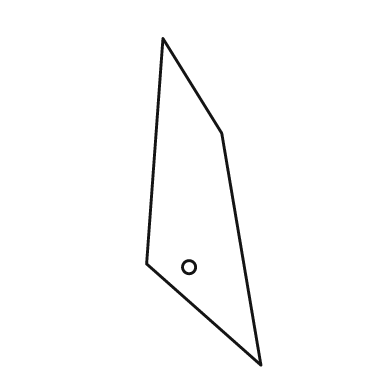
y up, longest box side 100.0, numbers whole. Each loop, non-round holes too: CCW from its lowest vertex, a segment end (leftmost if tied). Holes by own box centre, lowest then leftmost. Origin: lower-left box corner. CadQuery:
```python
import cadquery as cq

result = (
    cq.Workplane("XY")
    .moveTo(35.0, 0.0)
    .lineTo(23.0, 71.0)
    .lineTo(5.0, 100.0)
    .lineTo(0.0, 31.0)
    .close()
    .moveTo(13.0, 30.0)
    .circle(2.0)
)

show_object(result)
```